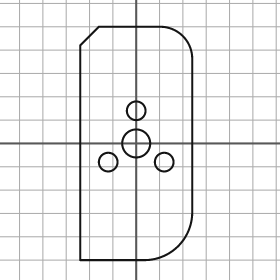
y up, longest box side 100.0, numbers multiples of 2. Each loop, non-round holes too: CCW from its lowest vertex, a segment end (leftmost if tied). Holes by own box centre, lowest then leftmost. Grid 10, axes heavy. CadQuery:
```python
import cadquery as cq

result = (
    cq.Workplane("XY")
    .moveTo(-24.0, -50.0)
    .lineTo(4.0, -50.0)
    .threePointArc((18.0, -44.0), (24.0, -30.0))
    .lineTo(24.0, 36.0)
    .threePointArc((20.0, 46.0), (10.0, 50.0))
    .lineTo(-16.0, 50.0)
    .lineTo(-24.0, 42.0)
    .close()
    .moveTo(-12.0, -8.0)
    .circle(4.0)
    .moveTo(12.0, -8.0)
    .circle(4.0)
    .moveTo(0.0, 0.0)
    .circle(6.0)
    .moveTo(0.0, 14.0)
    .circle(4.0)
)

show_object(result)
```